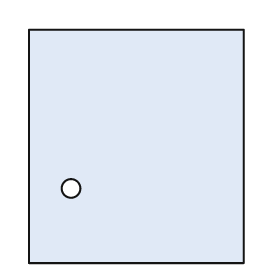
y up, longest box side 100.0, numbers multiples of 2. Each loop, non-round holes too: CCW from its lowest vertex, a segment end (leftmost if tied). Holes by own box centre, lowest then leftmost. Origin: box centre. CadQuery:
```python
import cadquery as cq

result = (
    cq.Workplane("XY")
    .moveTo(-46.0, -50.0)
    .lineTo(46.0, -50.0)
    .lineTo(46.0, 50.0)
    .lineTo(-46.0, 50.0)
    .close()
    .moveTo(-28.0, -18.0)
    .circle(4.0)
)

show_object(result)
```